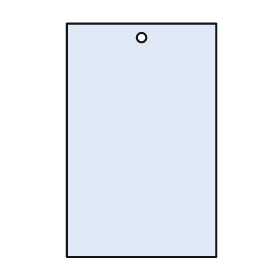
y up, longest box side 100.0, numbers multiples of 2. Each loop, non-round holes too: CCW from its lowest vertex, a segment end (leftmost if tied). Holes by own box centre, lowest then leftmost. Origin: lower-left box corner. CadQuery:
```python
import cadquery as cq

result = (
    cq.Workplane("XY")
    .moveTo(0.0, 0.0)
    .lineTo(64.0, 0.0)
    .lineTo(64.0, 100.0)
    .lineTo(0.0, 100.0)
    .close()
    .moveTo(32.0, 94.0)
    .circle(2.0)
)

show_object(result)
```